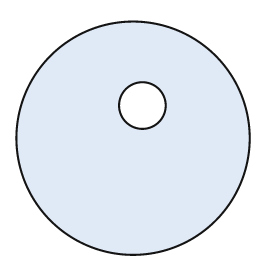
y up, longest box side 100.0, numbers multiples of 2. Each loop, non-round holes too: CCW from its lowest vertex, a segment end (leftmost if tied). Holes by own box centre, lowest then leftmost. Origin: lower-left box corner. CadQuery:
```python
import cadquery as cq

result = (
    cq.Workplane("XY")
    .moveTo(50.0, 50.0)
    .circle(50.0)
    .moveTo(54.0, 64.0)
    .circle(10.0)
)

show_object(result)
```